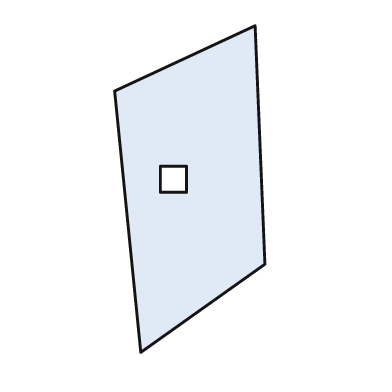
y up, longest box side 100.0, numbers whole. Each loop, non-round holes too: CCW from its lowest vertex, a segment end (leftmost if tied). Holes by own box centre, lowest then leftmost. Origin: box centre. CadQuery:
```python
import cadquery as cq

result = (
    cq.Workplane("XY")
    .moveTo(-15.0, -50.0)
    .lineTo(23.0, -23.0)
    .lineTo(20.0, 50.0)
    .lineTo(-23.0, 30.0)
    .close()
    .moveTo(-9.0, -1.0)
    .lineTo(-1.0, -1.0)
    .lineTo(-1.0, 7.0)
    .lineTo(-9.0, 7.0)
    .close()
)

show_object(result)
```